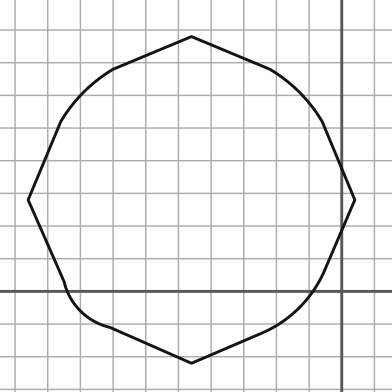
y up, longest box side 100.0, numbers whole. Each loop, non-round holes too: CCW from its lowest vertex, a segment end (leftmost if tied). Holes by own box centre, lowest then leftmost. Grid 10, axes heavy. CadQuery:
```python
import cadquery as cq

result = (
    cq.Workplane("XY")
    .moveTo(-46.0, -22.0)
    .lineTo(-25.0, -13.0)
    .threePointArc((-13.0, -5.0), (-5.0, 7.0))
    .lineTo(4.0, 28.0)
    .lineTo(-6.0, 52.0)
    .threePointArc((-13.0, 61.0), (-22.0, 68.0))
    .lineTo(-46.0, 78.0)
    .lineTo(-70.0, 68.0)
    .threePointArc((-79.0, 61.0), (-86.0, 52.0))
    .lineTo(-96.0, 28.0)
    .lineTo(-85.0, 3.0)
    .threePointArc((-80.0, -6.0), (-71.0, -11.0))
    .close()
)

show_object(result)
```